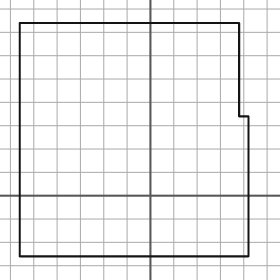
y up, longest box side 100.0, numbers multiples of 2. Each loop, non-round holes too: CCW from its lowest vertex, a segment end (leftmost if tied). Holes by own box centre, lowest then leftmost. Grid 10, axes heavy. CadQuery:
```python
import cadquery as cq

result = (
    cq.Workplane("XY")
    .moveTo(-56.0, -26.0)
    .lineTo(42.0, -26.0)
    .lineTo(42.0, 34.0)
    .lineTo(38.0, 34.0)
    .lineTo(38.0, 74.0)
    .lineTo(-56.0, 74.0)
    .close()
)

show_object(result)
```